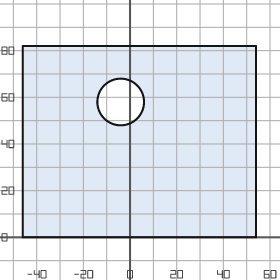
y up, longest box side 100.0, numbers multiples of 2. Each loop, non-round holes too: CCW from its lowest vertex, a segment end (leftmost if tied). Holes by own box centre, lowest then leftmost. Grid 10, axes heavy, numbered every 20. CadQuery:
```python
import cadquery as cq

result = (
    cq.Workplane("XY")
    .moveTo(-46.0, 0.0)
    .lineTo(54.0, 0.0)
    .lineTo(54.0, 82.0)
    .lineTo(-46.0, 82.0)
    .close()
    .moveTo(-4.0, 58.0)
    .circle(10.0)
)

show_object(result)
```